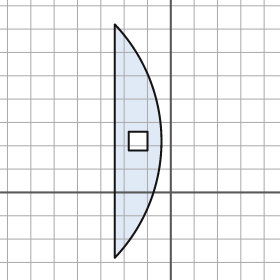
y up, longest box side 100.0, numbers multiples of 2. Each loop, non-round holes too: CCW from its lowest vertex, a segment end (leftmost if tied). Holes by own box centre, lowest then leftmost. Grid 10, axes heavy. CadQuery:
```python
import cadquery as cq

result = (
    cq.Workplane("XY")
    .moveTo(-24.0, -28.0)
    .threePointArc((-4.0, 22.0), (-24.0, 72.0))
    .close()
    .moveTo(-18.0, 18.0)
    .lineTo(-10.0, 18.0)
    .lineTo(-10.0, 26.0)
    .lineTo(-18.0, 26.0)
    .close()
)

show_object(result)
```